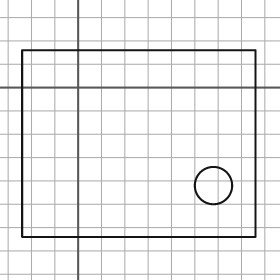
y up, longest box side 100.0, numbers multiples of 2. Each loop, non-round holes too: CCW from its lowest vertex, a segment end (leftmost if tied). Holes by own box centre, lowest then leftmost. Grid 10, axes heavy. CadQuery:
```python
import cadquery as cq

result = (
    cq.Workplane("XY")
    .moveTo(-24.0, -64.0)
    .lineTo(76.0, -64.0)
    .lineTo(76.0, 16.0)
    .lineTo(-24.0, 16.0)
    .close()
    .moveTo(58.0, -42.0)
    .circle(8.0)
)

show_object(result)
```